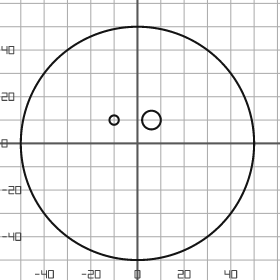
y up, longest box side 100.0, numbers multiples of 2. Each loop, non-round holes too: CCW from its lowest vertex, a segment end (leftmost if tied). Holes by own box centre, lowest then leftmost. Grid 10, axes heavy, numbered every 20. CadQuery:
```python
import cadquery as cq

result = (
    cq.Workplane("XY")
    .moveTo(0.0, 0.0)
    .circle(50.0)
    .moveTo(-10.0, 10.0)
    .circle(2.0)
    .moveTo(6.0, 10.0)
    .circle(4.0)
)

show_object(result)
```